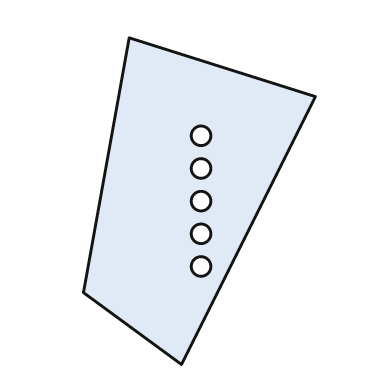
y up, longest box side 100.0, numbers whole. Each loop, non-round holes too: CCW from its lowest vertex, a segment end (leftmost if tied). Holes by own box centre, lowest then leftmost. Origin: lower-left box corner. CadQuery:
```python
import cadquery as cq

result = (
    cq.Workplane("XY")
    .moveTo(30.0, 0.0)
    .lineTo(71.0, 82.0)
    .lineTo(14.0, 100.0)
    .lineTo(0.0, 22.0)
    .close()
    .moveTo(36.0, 30.0)
    .circle(3.0)
    .moveTo(36.0, 40.0)
    .circle(3.0)
    .moveTo(36.0, 50.0)
    .circle(3.0)
    .moveTo(36.0, 60.0)
    .circle(3.0)
    .moveTo(36.0, 70.0)
    .circle(3.0)
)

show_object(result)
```